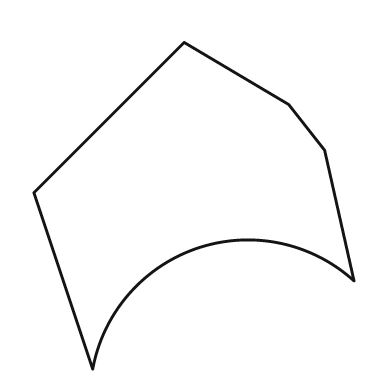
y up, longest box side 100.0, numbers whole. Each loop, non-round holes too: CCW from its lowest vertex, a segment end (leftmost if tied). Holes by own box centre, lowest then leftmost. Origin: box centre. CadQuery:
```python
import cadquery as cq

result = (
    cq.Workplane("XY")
    .moveTo(-31.0, -50.0)
    .threePointArc((1.0, -13.0), (49.0, -23.0))
    .lineTo(40.0, 17.0)
    .lineTo(29.0, 31.0)
    .lineTo(-3.0, 50.0)
    .lineTo(-49.0, 4.0)
    .close()
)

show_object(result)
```